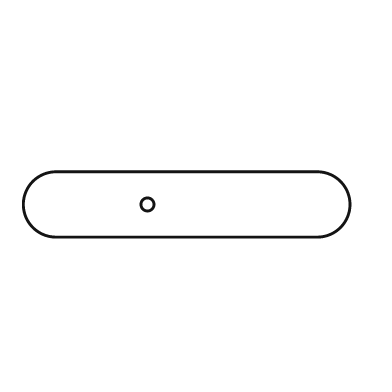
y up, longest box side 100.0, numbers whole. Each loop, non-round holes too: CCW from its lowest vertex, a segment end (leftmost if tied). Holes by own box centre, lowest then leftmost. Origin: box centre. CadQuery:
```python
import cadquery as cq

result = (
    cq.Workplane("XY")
    .moveTo(-40.0, -10.0)
    .lineTo(40.0, -10.0)
    .threePointArc((50.0, 0.0), (40.0, 10.0))
    .lineTo(-40.0, 10.0)
    .threePointArc((-50.0, 0.0), (-40.0, -10.0))
    .close()
    .moveTo(-12.0, 0.0)
    .circle(2.0)
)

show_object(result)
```